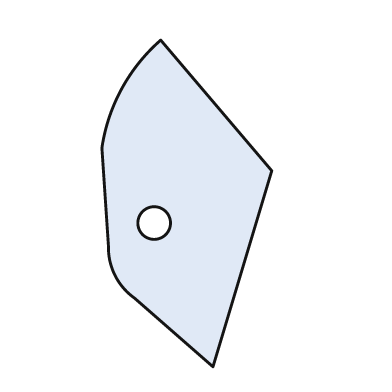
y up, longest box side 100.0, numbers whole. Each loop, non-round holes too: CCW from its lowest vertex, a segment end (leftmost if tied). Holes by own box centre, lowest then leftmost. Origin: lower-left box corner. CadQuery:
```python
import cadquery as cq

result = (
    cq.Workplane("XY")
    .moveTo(34.0, 0.0)
    .lineTo(52.0, 60.0)
    .lineTo(18.0, 100.0)
    .threePointArc((6.0, 85.0), (0.0, 67.0))
    .lineTo(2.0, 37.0)
    .threePointArc((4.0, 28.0), (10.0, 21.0))
    .close()
    .moveTo(16.0, 44.0)
    .circle(5.0)
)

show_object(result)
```